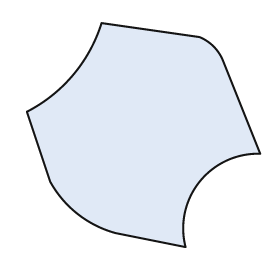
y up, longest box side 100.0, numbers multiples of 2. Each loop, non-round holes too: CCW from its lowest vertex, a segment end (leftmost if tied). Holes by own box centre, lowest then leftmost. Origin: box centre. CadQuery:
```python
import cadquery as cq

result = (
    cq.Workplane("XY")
    .moveTo(18.0, -48.0)
    .threePointArc((24.0, -20.0), (50.0, -8.0))
    .lineTo(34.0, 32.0)
    .threePointArc((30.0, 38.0), (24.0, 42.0))
    .lineTo(-18.0, 48.0)
    .threePointArc((-30.0, 26.0), (-50.0, 10.0))
    .lineTo(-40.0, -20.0)
    .threePointArc((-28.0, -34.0), (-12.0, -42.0))
    .close()
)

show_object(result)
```